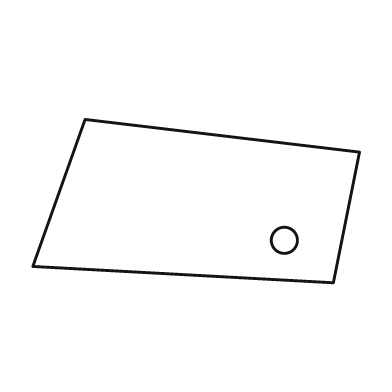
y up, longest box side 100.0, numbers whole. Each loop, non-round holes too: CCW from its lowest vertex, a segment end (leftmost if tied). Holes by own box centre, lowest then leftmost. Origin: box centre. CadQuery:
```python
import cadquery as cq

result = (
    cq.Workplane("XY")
    .moveTo(42.0, -25.0)
    .lineTo(50.0, 15.0)
    .lineTo(-34.0, 25.0)
    .lineTo(-50.0, -20.0)
    .close()
    .moveTo(27.0, -12.0)
    .circle(4.0)
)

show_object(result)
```